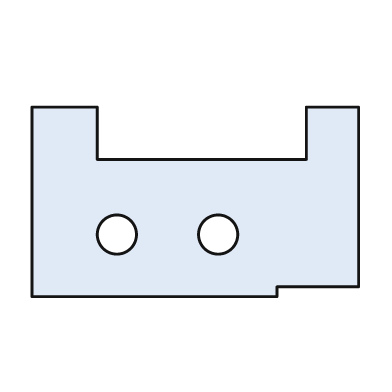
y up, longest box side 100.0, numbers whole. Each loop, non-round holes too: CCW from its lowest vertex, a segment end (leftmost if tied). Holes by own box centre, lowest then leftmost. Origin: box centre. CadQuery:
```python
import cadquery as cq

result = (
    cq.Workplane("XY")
    .moveTo(-50.0, -29.0)
    .lineTo(25.0, -29.0)
    .lineTo(25.0, -26.0)
    .lineTo(50.0, -26.0)
    .lineTo(50.0, 29.0)
    .lineTo(34.0, 29.0)
    .lineTo(34.0, 13.0)
    .lineTo(-30.0, 13.0)
    .lineTo(-30.0, 29.0)
    .lineTo(-50.0, 29.0)
    .close()
    .moveTo(-24.0, -10.0)
    .circle(6.0)
    .moveTo(7.0, -10.0)
    .circle(6.0)
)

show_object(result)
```